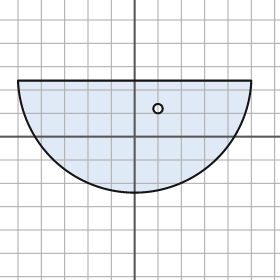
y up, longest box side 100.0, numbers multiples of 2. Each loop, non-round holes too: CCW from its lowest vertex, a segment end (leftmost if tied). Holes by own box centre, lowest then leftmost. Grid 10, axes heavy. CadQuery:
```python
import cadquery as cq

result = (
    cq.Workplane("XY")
    .moveTo(-50.0, 24.0)
    .threePointArc((0.0, -24.0), (50.0, 24.0))
    .close()
    .moveTo(10.0, 12.0)
    .circle(2.0)
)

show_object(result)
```